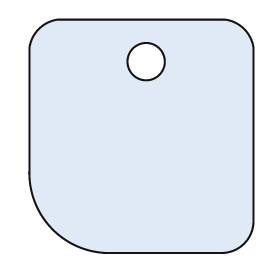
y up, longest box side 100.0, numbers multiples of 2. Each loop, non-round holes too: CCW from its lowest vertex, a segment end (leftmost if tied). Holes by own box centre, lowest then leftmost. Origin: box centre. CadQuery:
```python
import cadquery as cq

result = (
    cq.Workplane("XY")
    .moveTo(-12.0, -50.0)
    .lineTo(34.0, -50.0)
    .threePointArc((44.0, -46.0), (48.0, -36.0))
    .lineTo(48.0, 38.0)
    .threePointArc((44.0, 46.0), (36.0, 50.0))
    .lineTo(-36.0, 50.0)
    .threePointArc((-44.0, 46.0), (-48.0, 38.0))
    .lineTo(-48.0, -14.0)
    .threePointArc((-38.0, -40.0), (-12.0, -50.0))
    .close()
    .moveTo(2.0, 32.0)
    .circle(8.0)
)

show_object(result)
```